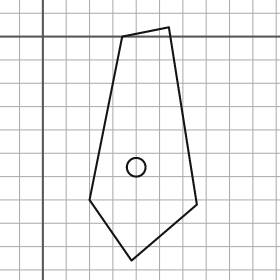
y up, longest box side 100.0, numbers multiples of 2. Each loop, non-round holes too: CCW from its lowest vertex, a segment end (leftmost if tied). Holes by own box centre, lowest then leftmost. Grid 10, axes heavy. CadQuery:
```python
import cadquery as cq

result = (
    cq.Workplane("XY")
    .moveTo(38.0, -96.0)
    .lineTo(66.0, -72.0)
    .lineTo(54.0, 4.0)
    .lineTo(34.0, 0.0)
    .lineTo(20.0, -70.0)
    .close()
    .moveTo(40.0, -56.0)
    .circle(4.0)
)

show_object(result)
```